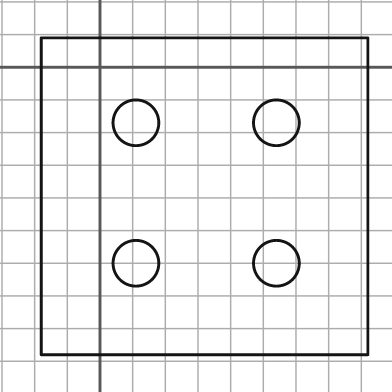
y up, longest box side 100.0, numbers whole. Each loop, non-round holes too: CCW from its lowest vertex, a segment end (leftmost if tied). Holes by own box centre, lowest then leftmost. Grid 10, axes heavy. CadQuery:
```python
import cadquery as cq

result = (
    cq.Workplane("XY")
    .moveTo(-18.0, -88.0)
    .lineTo(82.0, -88.0)
    .lineTo(82.0, 9.0)
    .lineTo(-18.0, 9.0)
    .close()
    .moveTo(11.0, -60.0)
    .circle(7.0)
    .moveTo(54.0, -60.0)
    .circle(7.0)
    .moveTo(11.0, -17.0)
    .circle(7.0)
    .moveTo(54.0, -17.0)
    .circle(7.0)
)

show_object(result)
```